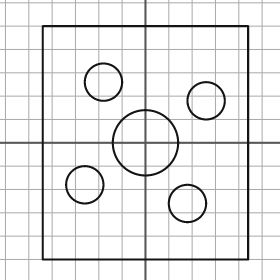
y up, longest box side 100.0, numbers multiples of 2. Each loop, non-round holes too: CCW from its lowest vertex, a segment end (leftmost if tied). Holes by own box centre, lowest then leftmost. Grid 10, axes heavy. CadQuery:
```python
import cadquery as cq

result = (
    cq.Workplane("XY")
    .moveTo(-44.0, -50.0)
    .lineTo(44.0, -50.0)
    .lineTo(44.0, 50.0)
    .lineTo(-44.0, 50.0)
    .close()
    .moveTo(18.0, -26.0)
    .circle(8.0)
    .moveTo(-26.0, -18.0)
    .circle(8.0)
    .moveTo(0.0, 0.0)
    .circle(14.0)
    .moveTo(26.0, 18.0)
    .circle(8.0)
    .moveTo(-18.0, 26.0)
    .circle(8.0)
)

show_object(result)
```